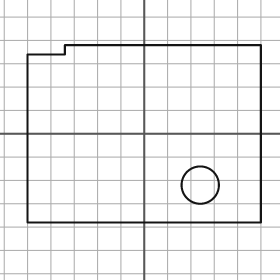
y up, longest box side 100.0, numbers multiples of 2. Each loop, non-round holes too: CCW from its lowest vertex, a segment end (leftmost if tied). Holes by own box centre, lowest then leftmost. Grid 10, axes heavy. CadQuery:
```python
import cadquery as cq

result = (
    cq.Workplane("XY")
    .moveTo(-50.0, -38.0)
    .lineTo(50.0, -38.0)
    .lineTo(50.0, 38.0)
    .lineTo(-34.0, 38.0)
    .lineTo(-34.0, 34.0)
    .lineTo(-50.0, 34.0)
    .close()
    .moveTo(24.0, -22.0)
    .circle(8.0)
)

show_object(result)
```